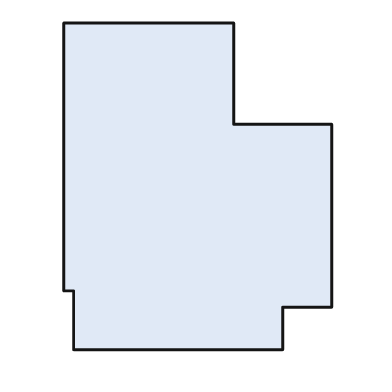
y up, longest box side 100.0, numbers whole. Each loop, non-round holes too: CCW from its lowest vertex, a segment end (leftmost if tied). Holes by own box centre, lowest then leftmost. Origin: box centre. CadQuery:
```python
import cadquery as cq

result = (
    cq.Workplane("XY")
    .moveTo(-38.0, -50.0)
    .lineTo(26.0, -50.0)
    .lineTo(26.0, -37.0)
    .lineTo(41.0, -37.0)
    .lineTo(41.0, 19.0)
    .lineTo(11.0, 19.0)
    .lineTo(11.0, 50.0)
    .lineTo(-41.0, 50.0)
    .lineTo(-41.0, -32.0)
    .lineTo(-38.0, -32.0)
    .close()
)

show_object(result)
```